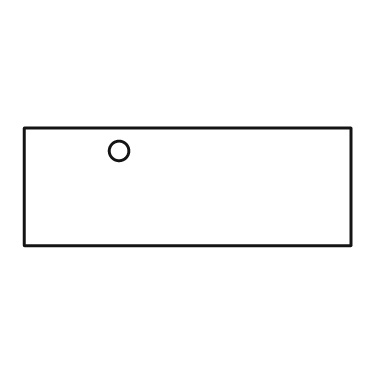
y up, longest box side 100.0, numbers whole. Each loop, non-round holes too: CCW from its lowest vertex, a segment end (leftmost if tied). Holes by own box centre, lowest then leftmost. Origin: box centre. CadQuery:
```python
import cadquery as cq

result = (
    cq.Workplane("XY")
    .moveTo(-50.0, -18.0)
    .lineTo(50.0, -18.0)
    .lineTo(50.0, 18.0)
    .lineTo(-50.0, 18.0)
    .close()
    .moveTo(-21.0, 11.0)
    .circle(3.0)
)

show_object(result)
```